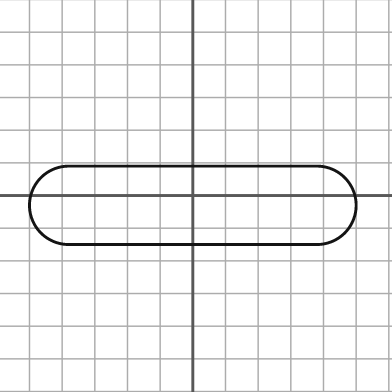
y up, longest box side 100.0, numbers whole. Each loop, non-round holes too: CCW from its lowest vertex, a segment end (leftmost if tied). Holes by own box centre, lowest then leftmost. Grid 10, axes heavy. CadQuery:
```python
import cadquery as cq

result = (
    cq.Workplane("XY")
    .moveTo(-38.0, -15.0)
    .lineTo(38.0, -15.0)
    .threePointArc((50.0, -3.0), (38.0, 9.0))
    .lineTo(-38.0, 9.0)
    .threePointArc((-50.0, -3.0), (-38.0, -15.0))
    .close()
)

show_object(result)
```